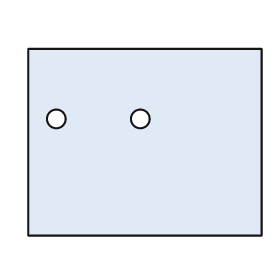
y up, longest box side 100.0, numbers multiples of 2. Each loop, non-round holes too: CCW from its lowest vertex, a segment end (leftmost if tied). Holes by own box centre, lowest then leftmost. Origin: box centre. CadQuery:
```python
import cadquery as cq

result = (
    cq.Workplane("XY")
    .moveTo(-50.0, -40.0)
    .lineTo(50.0, -40.0)
    .lineTo(50.0, 40.0)
    .lineTo(-50.0, 40.0)
    .close()
    .moveTo(-38.0, 10.0)
    .circle(4.0)
    .moveTo(-2.0, 10.0)
    .circle(4.0)
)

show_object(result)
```